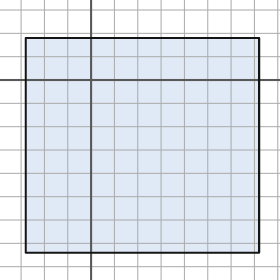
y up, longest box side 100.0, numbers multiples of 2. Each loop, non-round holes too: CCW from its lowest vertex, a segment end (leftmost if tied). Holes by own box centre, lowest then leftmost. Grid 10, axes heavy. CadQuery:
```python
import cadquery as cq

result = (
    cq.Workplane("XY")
    .moveTo(-28.0, -74.0)
    .lineTo(72.0, -74.0)
    .lineTo(72.0, 18.0)
    .lineTo(-28.0, 18.0)
    .close()
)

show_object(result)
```